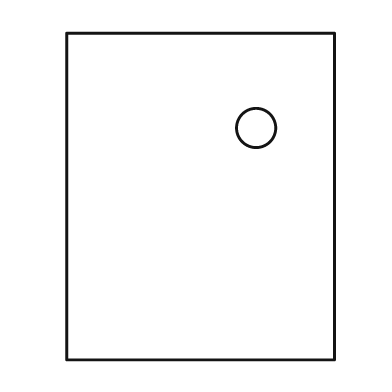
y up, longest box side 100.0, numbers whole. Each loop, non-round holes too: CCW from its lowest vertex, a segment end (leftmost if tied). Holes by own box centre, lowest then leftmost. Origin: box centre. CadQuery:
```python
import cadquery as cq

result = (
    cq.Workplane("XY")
    .moveTo(-41.0, -50.0)
    .lineTo(41.0, -50.0)
    .lineTo(41.0, 50.0)
    .lineTo(-41.0, 50.0)
    .close()
    .moveTo(17.0, 21.0)
    .circle(6.0)
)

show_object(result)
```